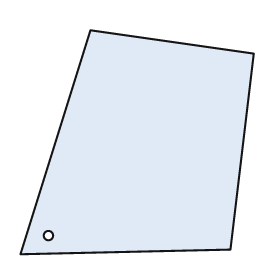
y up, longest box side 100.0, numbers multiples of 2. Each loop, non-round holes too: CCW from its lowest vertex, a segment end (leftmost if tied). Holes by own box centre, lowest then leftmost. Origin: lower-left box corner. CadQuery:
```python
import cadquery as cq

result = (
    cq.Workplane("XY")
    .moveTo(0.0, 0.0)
    .lineTo(90.0, 2.0)
    .lineTo(100.0, 86.0)
    .lineTo(30.0, 96.0)
    .close()
    .moveTo(12.0, 8.0)
    .circle(2.0)
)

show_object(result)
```